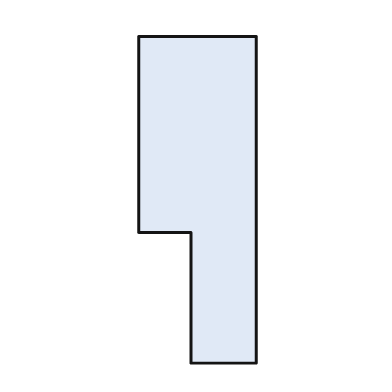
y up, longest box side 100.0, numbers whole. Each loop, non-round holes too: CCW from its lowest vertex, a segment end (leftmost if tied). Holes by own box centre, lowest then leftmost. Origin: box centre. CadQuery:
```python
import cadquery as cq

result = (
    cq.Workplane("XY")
    .moveTo(-2.0, -50.0)
    .lineTo(18.0, -50.0)
    .lineTo(18.0, 50.0)
    .lineTo(-18.0, 50.0)
    .lineTo(-18.0, -10.0)
    .lineTo(-2.0, -10.0)
    .close()
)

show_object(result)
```